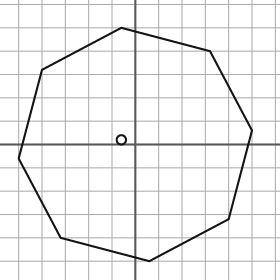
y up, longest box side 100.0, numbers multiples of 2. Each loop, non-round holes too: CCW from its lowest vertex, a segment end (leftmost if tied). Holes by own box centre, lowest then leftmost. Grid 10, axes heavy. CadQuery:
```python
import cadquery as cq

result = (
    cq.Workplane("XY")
    .moveTo(6.0, -50.0)
    .lineTo(40.0, -32.0)
    .lineTo(50.0, 6.0)
    .lineTo(32.0, 40.0)
    .lineTo(-6.0, 50.0)
    .lineTo(-40.0, 32.0)
    .lineTo(-50.0, -6.0)
    .lineTo(-32.0, -40.0)
    .close()
    .moveTo(-6.0, 2.0)
    .circle(2.0)
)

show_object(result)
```